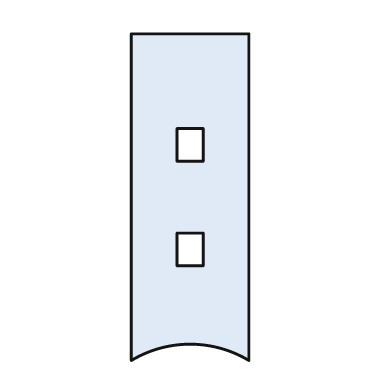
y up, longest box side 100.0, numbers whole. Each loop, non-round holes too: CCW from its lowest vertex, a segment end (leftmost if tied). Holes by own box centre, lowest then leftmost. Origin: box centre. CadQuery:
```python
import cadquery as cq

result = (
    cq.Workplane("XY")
    .moveTo(-18.0, -50.0)
    .threePointArc((0.0, -45.0), (18.0, -50.0))
    .lineTo(18.0, 50.0)
    .lineTo(-18.0, 50.0)
    .close()
    .moveTo(-4.0, -21.0)
    .lineTo(4.0, -21.0)
    .lineTo(4.0, -11.0)
    .lineTo(-4.0, -11.0)
    .close()
    .moveTo(-4.0, 11.0)
    .lineTo(4.0, 11.0)
    .lineTo(4.0, 21.0)
    .lineTo(-4.0, 21.0)
    .close()
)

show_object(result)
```